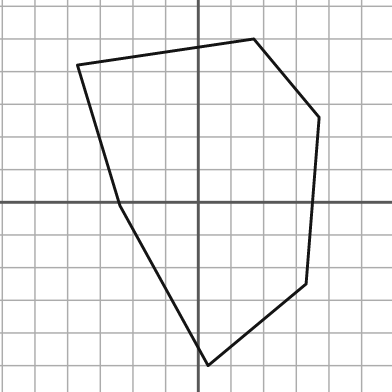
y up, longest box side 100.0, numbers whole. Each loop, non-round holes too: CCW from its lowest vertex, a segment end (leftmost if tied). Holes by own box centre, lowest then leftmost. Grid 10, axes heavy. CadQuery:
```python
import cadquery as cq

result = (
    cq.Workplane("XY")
    .moveTo(3.0, -50.0)
    .lineTo(33.0, -25.0)
    .lineTo(37.0, 26.0)
    .lineTo(17.0, 50.0)
    .lineTo(-37.0, 42.0)
    .lineTo(-24.0, -1.0)
    .close()
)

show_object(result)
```